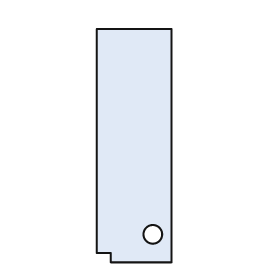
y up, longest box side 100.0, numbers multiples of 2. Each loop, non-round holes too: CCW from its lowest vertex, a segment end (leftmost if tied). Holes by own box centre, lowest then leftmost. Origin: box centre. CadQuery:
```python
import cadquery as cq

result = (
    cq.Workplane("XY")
    .moveTo(-10.0, -50.0)
    .lineTo(16.0, -50.0)
    .lineTo(16.0, 50.0)
    .lineTo(-16.0, 50.0)
    .lineTo(-16.0, -46.0)
    .lineTo(-10.0, -46.0)
    .close()
    .moveTo(8.0, -38.0)
    .circle(4.0)
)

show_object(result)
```